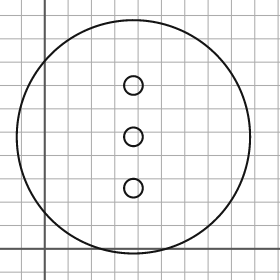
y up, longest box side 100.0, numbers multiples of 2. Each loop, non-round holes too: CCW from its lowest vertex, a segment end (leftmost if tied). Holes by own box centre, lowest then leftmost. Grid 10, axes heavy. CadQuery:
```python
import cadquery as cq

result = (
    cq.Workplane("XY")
    .moveTo(38.0, 48.0)
    .circle(50.0)
    .moveTo(38.0, 26.0)
    .circle(4.0)
    .moveTo(38.0, 48.0)
    .circle(4.0)
    .moveTo(38.0, 70.0)
    .circle(4.0)
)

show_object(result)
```